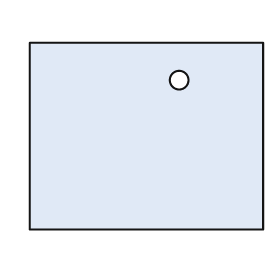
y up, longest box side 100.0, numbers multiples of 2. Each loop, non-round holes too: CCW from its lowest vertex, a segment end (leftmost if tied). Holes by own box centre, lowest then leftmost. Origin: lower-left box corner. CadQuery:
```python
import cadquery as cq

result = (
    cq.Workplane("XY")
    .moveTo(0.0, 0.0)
    .lineTo(100.0, 0.0)
    .lineTo(100.0, 80.0)
    .lineTo(0.0, 80.0)
    .close()
    .moveTo(64.0, 64.0)
    .circle(4.0)
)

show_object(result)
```